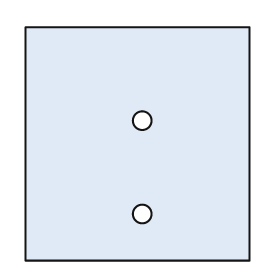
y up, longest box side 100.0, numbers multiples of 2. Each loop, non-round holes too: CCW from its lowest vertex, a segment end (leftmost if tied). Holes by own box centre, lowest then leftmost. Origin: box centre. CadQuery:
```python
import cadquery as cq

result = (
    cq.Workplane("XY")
    .moveTo(-48.0, -50.0)
    .lineTo(48.0, -50.0)
    .lineTo(48.0, 50.0)
    .lineTo(-48.0, 50.0)
    .close()
    .moveTo(2.0, -30.0)
    .circle(4.0)
    .moveTo(2.0, 10.0)
    .circle(4.0)
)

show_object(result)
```